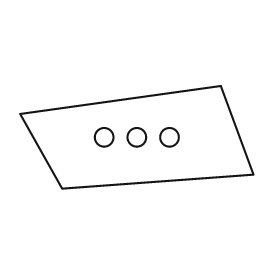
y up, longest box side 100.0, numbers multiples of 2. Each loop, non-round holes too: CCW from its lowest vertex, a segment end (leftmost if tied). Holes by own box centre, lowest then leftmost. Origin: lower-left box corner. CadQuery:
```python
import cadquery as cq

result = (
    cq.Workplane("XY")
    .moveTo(18.0, 0.0)
    .lineTo(100.0, 6.0)
    .lineTo(86.0, 44.0)
    .lineTo(0.0, 32.0)
    .close()
    .moveTo(36.0, 22.0)
    .circle(4.0)
    .moveTo(50.0, 22.0)
    .circle(4.0)
    .moveTo(64.0, 22.0)
    .circle(4.0)
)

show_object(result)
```